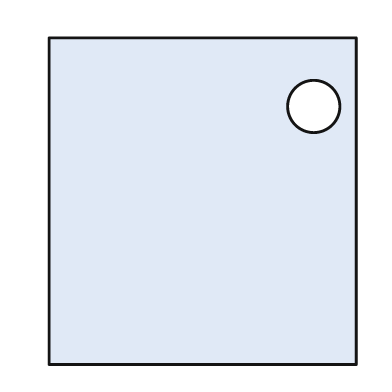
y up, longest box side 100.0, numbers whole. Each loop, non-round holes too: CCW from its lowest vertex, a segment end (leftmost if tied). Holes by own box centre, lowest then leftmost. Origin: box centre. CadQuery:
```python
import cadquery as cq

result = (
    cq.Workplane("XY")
    .moveTo(-47.0, -50.0)
    .lineTo(47.0, -50.0)
    .lineTo(47.0, 50.0)
    .lineTo(-47.0, 50.0)
    .close()
    .moveTo(34.0, 29.0)
    .circle(8.0)
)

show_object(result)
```